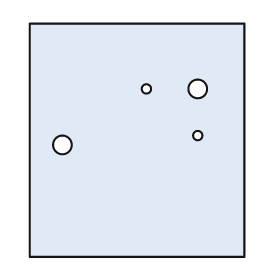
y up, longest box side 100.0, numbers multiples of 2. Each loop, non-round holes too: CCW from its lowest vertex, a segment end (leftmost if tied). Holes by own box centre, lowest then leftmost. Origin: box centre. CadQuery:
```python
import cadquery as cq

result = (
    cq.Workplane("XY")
    .moveTo(-46.0, -50.0)
    .lineTo(46.0, -50.0)
    .lineTo(46.0, 50.0)
    .lineTo(-46.0, 50.0)
    .close()
    .moveTo(-32.0, -2.0)
    .circle(4.0)
    .moveTo(26.0, 2.0)
    .circle(2.0)
    .moveTo(4.0, 22.0)
    .circle(2.0)
    .moveTo(26.0, 22.0)
    .circle(4.0)
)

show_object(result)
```